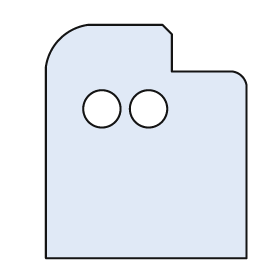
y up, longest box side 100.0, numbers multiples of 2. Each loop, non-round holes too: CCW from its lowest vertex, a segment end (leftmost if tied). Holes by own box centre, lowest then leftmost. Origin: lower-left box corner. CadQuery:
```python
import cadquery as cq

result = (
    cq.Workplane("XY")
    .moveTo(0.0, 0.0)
    .lineTo(86.0, 0.0)
    .lineTo(86.0, 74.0)
    .threePointArc((84.0, 78.0), (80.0, 80.0))
    .lineTo(54.0, 80.0)
    .lineTo(54.0, 96.0)
    .lineTo(50.0, 100.0)
    .lineTo(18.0, 100.0)
    .threePointArc((6.0, 94.0), (0.0, 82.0))
    .close()
    .moveTo(24.0, 64.0)
    .circle(8.0)
    .moveTo(44.0, 64.0)
    .circle(8.0)
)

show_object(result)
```